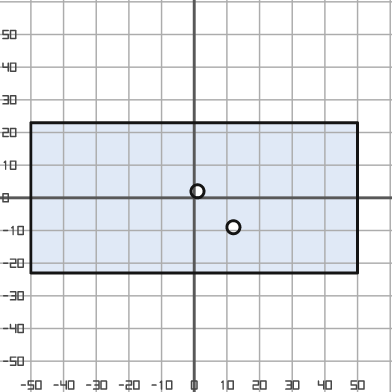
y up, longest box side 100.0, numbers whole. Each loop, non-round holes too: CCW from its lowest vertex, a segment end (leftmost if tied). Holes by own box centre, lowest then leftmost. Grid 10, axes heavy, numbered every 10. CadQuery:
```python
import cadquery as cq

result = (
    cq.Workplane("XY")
    .moveTo(-50.0, -23.0)
    .lineTo(50.0, -23.0)
    .lineTo(50.0, 23.0)
    .lineTo(-50.0, 23.0)
    .close()
    .moveTo(12.0, -9.0)
    .circle(2.0)
    .moveTo(1.0, 2.0)
    .circle(2.0)
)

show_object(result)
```